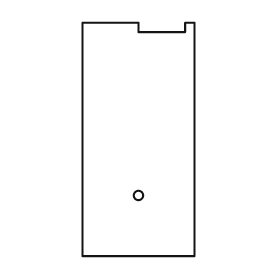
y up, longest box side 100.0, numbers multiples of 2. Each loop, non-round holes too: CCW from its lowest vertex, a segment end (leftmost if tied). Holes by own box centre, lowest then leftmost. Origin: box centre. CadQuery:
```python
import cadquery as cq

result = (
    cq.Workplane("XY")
    .moveTo(-24.0, -50.0)
    .lineTo(24.0, -50.0)
    .lineTo(24.0, 50.0)
    .lineTo(20.0, 50.0)
    .lineTo(20.0, 46.0)
    .lineTo(0.0, 46.0)
    .lineTo(0.0, 50.0)
    .lineTo(-24.0, 50.0)
    .close()
    .moveTo(0.0, -24.0)
    .circle(2.0)
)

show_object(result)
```